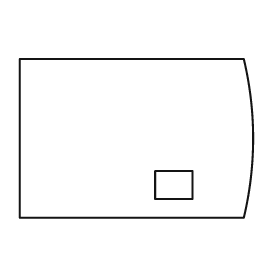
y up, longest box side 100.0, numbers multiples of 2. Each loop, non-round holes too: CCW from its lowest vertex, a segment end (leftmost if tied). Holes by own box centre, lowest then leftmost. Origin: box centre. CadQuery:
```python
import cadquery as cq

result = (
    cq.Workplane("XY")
    .moveTo(-50.0, -34.0)
    .lineTo(46.0, -34.0)
    .threePointArc((50.0, 0.0), (46.0, 34.0))
    .lineTo(-50.0, 34.0)
    .close()
    .moveTo(8.0, -26.0)
    .lineTo(24.0, -26.0)
    .lineTo(24.0, -14.0)
    .lineTo(8.0, -14.0)
    .close()
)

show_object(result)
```